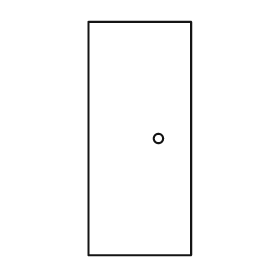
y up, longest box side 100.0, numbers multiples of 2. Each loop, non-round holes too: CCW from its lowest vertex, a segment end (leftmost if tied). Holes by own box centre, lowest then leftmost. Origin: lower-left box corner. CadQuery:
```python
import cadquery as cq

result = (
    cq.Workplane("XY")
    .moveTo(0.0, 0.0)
    .lineTo(44.0, 0.0)
    .lineTo(44.0, 100.0)
    .lineTo(0.0, 100.0)
    .close()
    .moveTo(30.0, 50.0)
    .circle(2.0)
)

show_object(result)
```